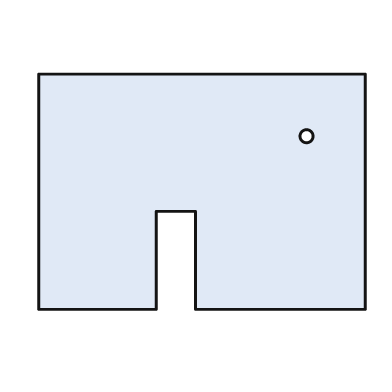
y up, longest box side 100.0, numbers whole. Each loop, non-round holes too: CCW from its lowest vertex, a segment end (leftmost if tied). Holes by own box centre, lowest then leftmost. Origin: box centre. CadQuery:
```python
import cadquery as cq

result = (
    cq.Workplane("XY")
    .moveTo(-50.0, -36.0)
    .lineTo(-14.0, -36.0)
    .lineTo(-14.0, -6.0)
    .lineTo(-2.0, -6.0)
    .lineTo(-2.0, -36.0)
    .lineTo(50.0, -36.0)
    .lineTo(50.0, 36.0)
    .lineTo(-50.0, 36.0)
    .close()
    .moveTo(32.0, 17.0)
    .circle(2.0)
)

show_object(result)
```